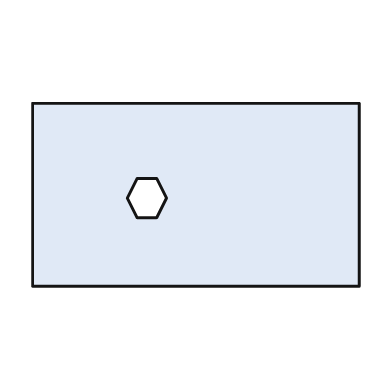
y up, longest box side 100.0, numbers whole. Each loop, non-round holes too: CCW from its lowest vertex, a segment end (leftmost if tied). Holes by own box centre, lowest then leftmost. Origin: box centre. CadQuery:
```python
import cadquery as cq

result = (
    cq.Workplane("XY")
    .moveTo(-50.0, -28.0)
    .lineTo(50.0, -28.0)
    .lineTo(50.0, 28.0)
    .lineTo(-50.0, 28.0)
    .close()
    .moveTo(-18.0, -7.0)
    .lineTo(-12.0, -7.0)
    .lineTo(-9.0, -1.0)
    .lineTo(-12.0, 5.0)
    .lineTo(-18.0, 5.0)
    .lineTo(-21.0, -1.0)
    .close()
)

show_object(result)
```